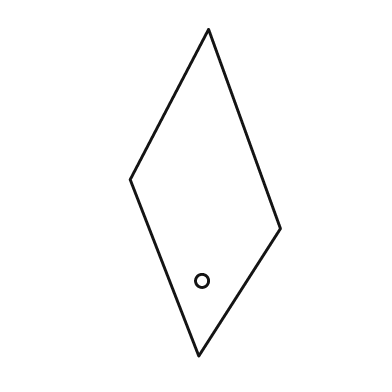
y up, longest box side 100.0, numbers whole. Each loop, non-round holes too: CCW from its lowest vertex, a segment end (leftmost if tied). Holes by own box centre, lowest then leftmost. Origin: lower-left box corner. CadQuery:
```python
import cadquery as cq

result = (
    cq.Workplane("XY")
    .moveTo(21.0, 0.0)
    .lineTo(46.0, 39.0)
    .lineTo(24.0, 100.0)
    .lineTo(0.0, 54.0)
    .close()
    .moveTo(22.0, 23.0)
    .circle(2.0)
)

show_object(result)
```